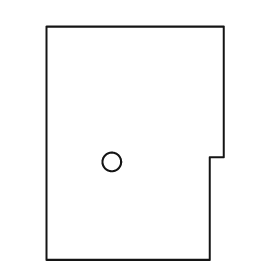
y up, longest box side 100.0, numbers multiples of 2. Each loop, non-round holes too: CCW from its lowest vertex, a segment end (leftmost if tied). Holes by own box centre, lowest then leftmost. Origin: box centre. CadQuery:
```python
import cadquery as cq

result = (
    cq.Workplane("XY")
    .moveTo(-38.0, -50.0)
    .lineTo(32.0, -50.0)
    .lineTo(32.0, -6.0)
    .lineTo(38.0, -6.0)
    .lineTo(38.0, 50.0)
    .lineTo(-38.0, 50.0)
    .close()
    .moveTo(-10.0, -8.0)
    .circle(4.0)
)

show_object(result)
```